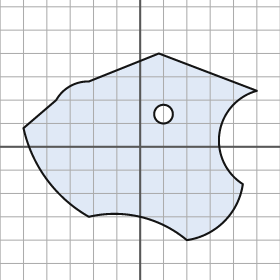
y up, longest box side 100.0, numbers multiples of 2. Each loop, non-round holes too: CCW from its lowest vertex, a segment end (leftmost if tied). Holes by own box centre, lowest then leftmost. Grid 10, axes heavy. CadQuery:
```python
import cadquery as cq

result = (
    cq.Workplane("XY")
    .moveTo(20.0, -40.0)
    .threePointArc((36.0, -32.0), (44.0, -16.0))
    .threePointArc((34.0, 6.0), (50.0, 24.0))
    .lineTo(8.0, 40.0)
    .lineTo(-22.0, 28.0)
    .threePointArc((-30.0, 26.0), (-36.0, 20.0))
    .lineTo(-50.0, 8.0)
    .threePointArc((-40.0, -14.0), (-22.0, -30.0))
    .threePointArc((0.0, -30.0), (20.0, -40.0))
    .close()
    .moveTo(10.0, 14.0)
    .circle(4.0)
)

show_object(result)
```